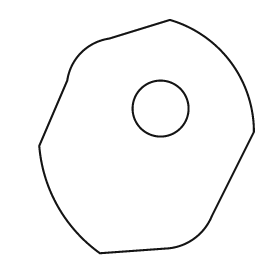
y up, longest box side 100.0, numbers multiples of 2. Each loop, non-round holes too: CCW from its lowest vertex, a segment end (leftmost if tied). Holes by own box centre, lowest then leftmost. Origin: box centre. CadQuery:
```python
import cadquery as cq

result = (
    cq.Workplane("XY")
    .moveTo(-20.0, -50.0)
    .lineTo(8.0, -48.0)
    .threePointArc((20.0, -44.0), (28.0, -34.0))
    .lineTo(46.0, 2.0)
    .threePointArc((36.0, 32.0), (10.0, 50.0))
    .lineTo(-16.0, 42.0)
    .threePointArc((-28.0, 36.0), (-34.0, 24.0))
    .lineTo(-46.0, -4.0)
    .threePointArc((-38.0, -30.0), (-20.0, -50.0))
    .close()
    .moveTo(6.0, 12.0)
    .circle(12.0)
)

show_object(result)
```